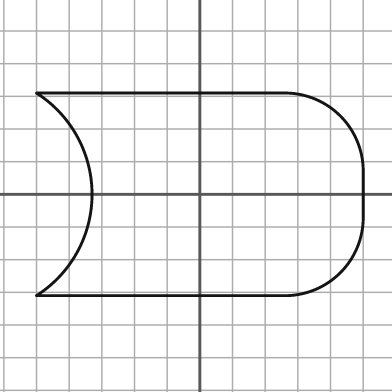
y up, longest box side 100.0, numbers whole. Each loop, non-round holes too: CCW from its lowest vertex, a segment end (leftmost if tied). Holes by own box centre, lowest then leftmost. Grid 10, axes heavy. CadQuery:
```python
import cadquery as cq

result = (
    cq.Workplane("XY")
    .moveTo(-50.0, -31.0)
    .lineTo(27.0, -31.0)
    .threePointArc((43.0, -24.0), (50.0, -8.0))
    .lineTo(50.0, 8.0)
    .threePointArc((43.0, 24.0), (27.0, 31.0))
    .lineTo(-50.0, 31.0)
    .threePointArc((-33.0, 0.0), (-50.0, -31.0))
    .close()
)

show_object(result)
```